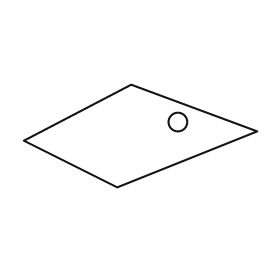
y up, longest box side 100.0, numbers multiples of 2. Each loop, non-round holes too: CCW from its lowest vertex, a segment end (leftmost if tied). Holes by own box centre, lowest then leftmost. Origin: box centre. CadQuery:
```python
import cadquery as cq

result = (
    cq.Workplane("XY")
    .moveTo(-10.0, -22.0)
    .lineTo(50.0, 2.0)
    .lineTo(-4.0, 22.0)
    .lineTo(-50.0, -2.0)
    .close()
    .moveTo(16.0, 6.0)
    .circle(4.0)
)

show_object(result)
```